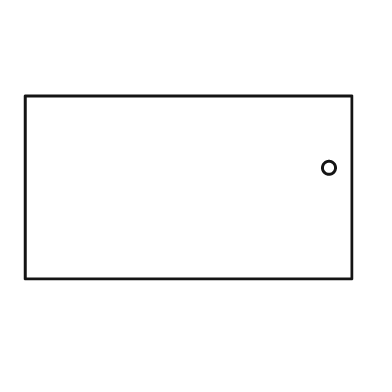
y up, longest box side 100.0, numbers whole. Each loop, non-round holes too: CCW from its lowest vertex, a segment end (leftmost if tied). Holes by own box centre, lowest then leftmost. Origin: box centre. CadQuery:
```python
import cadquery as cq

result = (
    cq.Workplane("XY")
    .moveTo(-50.0, -28.0)
    .lineTo(50.0, -28.0)
    .lineTo(50.0, 28.0)
    .lineTo(-50.0, 28.0)
    .close()
    .moveTo(43.0, 6.0)
    .circle(2.0)
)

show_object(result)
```